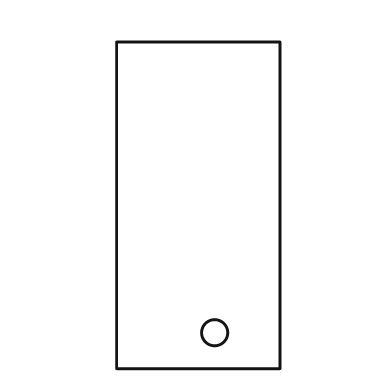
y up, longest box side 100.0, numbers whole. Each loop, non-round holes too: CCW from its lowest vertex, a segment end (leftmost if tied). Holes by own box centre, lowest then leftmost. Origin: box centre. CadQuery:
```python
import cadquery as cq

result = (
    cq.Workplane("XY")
    .moveTo(-25.0, -50.0)
    .lineTo(25.0, -50.0)
    .lineTo(25.0, 50.0)
    .lineTo(-25.0, 50.0)
    .close()
    .moveTo(5.0, -39.0)
    .circle(4.0)
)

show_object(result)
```